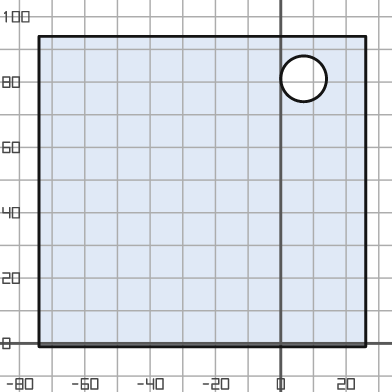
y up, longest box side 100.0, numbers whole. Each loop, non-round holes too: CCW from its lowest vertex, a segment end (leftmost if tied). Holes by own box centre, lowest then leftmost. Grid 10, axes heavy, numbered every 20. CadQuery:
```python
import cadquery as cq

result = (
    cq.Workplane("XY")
    .moveTo(-74.0, -1.0)
    .lineTo(26.0, -1.0)
    .lineTo(26.0, 94.0)
    .lineTo(-74.0, 94.0)
    .close()
    .moveTo(7.0, 81.0)
    .circle(7.0)
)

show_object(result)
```